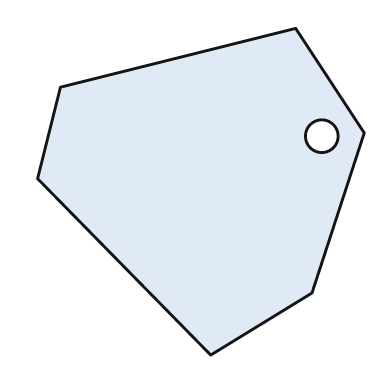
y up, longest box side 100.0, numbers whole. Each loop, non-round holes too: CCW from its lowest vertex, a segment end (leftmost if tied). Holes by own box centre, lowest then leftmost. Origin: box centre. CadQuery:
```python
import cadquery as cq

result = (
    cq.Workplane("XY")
    .moveTo(3.0, -50.0)
    .lineTo(34.0, -31.0)
    .lineTo(50.0, 18.0)
    .lineTo(29.0, 50.0)
    .lineTo(-43.0, 32.0)
    .lineTo(-50.0, 4.0)
    .close()
    .moveTo(37.0, 17.0)
    .circle(5.0)
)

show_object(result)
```